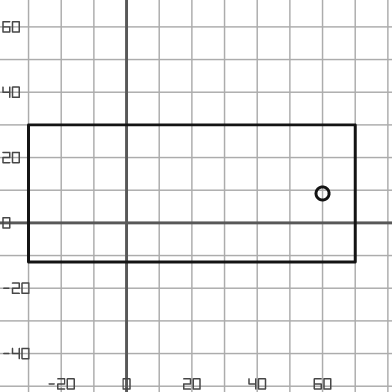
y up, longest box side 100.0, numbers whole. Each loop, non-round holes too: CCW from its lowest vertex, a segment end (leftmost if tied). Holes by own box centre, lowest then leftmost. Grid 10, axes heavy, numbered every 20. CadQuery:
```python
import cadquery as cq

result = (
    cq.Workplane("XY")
    .moveTo(-30.0, -12.0)
    .lineTo(70.0, -12.0)
    .lineTo(70.0, 30.0)
    .lineTo(-30.0, 30.0)
    .close()
    .moveTo(60.0, 9.0)
    .circle(2.0)
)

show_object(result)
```